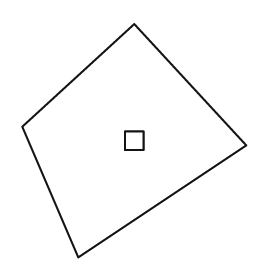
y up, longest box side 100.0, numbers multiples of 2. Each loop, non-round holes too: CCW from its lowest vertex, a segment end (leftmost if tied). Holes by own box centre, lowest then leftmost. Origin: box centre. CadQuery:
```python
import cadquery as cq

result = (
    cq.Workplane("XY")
    .moveTo(-24.0, -50.0)
    .lineTo(48.0, -2.0)
    .lineTo(0.0, 50.0)
    .lineTo(-48.0, 6.0)
    .close()
    .moveTo(-4.0, -4.0)
    .lineTo(4.0, -4.0)
    .lineTo(4.0, 4.0)
    .lineTo(-4.0, 4.0)
    .close()
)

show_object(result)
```